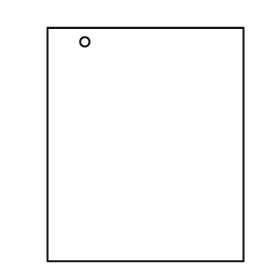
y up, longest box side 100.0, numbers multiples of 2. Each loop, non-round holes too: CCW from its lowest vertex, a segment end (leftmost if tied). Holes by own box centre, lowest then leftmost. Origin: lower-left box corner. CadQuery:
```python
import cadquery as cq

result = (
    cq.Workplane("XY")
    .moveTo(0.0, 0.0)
    .lineTo(84.0, 0.0)
    .lineTo(84.0, 100.0)
    .lineTo(0.0, 100.0)
    .close()
    .moveTo(16.0, 94.0)
    .circle(2.0)
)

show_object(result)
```